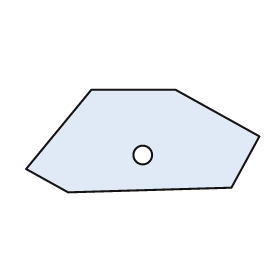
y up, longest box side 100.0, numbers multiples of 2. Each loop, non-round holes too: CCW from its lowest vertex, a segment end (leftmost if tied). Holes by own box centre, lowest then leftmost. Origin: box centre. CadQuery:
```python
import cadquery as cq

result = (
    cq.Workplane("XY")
    .moveTo(-32.0, -22.0)
    .lineTo(38.0, -20.0)
    .lineTo(50.0, 2.0)
    .lineTo(14.0, 22.0)
    .lineTo(-22.0, 22.0)
    .lineTo(-50.0, -12.0)
    .close()
    .moveTo(0.0, -6.0)
    .circle(4.0)
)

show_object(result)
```